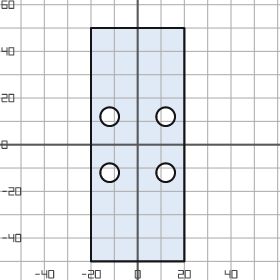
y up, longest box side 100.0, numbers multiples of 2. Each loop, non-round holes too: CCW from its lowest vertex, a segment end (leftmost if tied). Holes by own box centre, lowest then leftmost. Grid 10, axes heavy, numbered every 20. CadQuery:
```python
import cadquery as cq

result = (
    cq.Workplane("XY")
    .moveTo(-20.0, -50.0)
    .lineTo(20.0, -50.0)
    .lineTo(20.0, 50.0)
    .lineTo(-20.0, 50.0)
    .close()
    .moveTo(-12.0, -12.0)
    .circle(4.0)
    .moveTo(12.0, -12.0)
    .circle(4.0)
    .moveTo(-12.0, 12.0)
    .circle(4.0)
    .moveTo(12.0, 12.0)
    .circle(4.0)
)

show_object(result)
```